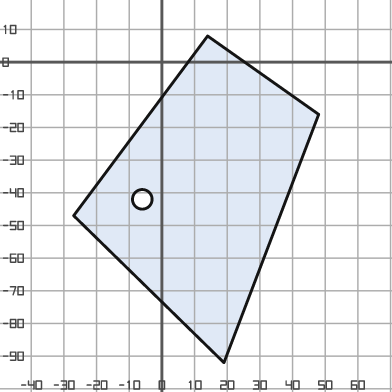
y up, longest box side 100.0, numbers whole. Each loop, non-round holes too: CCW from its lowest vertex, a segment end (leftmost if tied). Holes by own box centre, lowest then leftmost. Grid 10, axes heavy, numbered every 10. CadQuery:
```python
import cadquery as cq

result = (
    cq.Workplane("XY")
    .moveTo(19.0, -92.0)
    .lineTo(48.0, -16.0)
    .lineTo(14.0, 8.0)
    .lineTo(-27.0, -47.0)
    .close()
    .moveTo(-6.0, -42.0)
    .circle(3.0)
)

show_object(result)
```